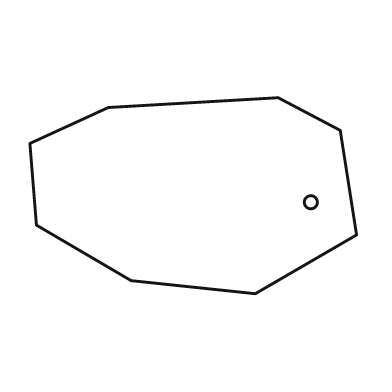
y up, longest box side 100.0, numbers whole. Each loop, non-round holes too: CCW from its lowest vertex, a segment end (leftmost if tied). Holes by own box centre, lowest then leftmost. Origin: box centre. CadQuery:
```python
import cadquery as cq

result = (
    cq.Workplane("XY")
    .moveTo(19.0, -30.0)
    .lineTo(50.0, -12.0)
    .lineTo(45.0, 20.0)
    .lineTo(26.0, 30.0)
    .lineTo(-26.0, 27.0)
    .lineTo(-50.0, 16.0)
    .lineTo(-48.0, -9.0)
    .lineTo(-19.0, -26.0)
    .close()
    .moveTo(36.0, -2.0)
    .circle(2.0)
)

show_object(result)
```